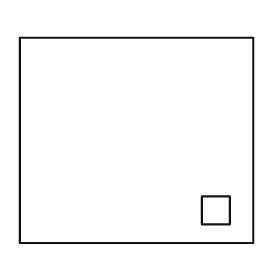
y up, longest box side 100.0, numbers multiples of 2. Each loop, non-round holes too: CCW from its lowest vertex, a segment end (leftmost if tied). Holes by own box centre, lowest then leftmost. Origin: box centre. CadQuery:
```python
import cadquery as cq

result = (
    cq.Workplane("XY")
    .moveTo(-50.0, -44.0)
    .lineTo(50.0, -44.0)
    .lineTo(50.0, 44.0)
    .lineTo(-50.0, 44.0)
    .close()
    .moveTo(28.0, -36.0)
    .lineTo(40.0, -36.0)
    .lineTo(40.0, -24.0)
    .lineTo(28.0, -24.0)
    .close()
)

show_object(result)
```